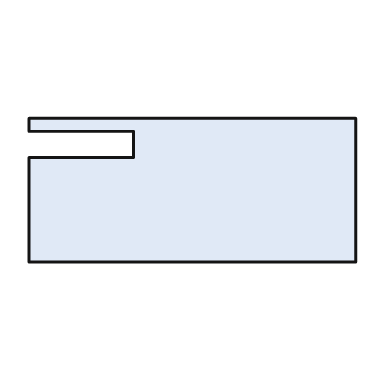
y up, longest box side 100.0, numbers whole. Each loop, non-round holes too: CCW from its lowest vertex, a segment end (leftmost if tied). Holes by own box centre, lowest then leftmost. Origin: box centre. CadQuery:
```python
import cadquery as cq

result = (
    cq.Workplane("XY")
    .moveTo(-50.0, -22.0)
    .lineTo(50.0, -22.0)
    .lineTo(50.0, 22.0)
    .lineTo(-50.0, 22.0)
    .lineTo(-50.0, 18.0)
    .lineTo(-18.0, 18.0)
    .lineTo(-18.0, 10.0)
    .lineTo(-50.0, 10.0)
    .close()
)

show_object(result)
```